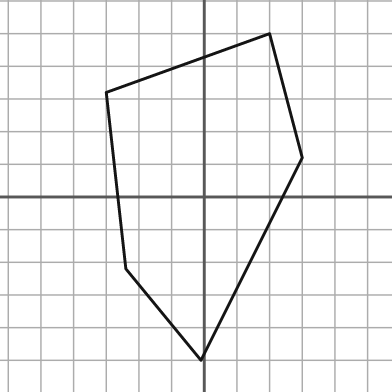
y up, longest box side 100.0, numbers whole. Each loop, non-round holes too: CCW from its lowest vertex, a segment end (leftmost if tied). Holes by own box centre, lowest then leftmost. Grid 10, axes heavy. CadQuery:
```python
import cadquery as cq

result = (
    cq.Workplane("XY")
    .moveTo(-1.0, -50.0)
    .lineTo(30.0, 12.0)
    .lineTo(20.0, 50.0)
    .lineTo(-30.0, 32.0)
    .lineTo(-24.0, -22.0)
    .close()
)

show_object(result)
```